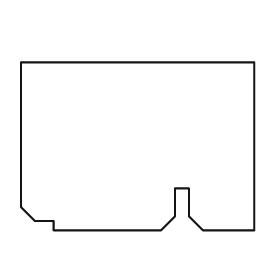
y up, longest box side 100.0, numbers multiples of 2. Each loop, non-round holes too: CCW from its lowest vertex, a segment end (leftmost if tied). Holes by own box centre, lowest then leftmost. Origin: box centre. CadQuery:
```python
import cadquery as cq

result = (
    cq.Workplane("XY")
    .moveTo(-36.0, -36.0)
    .lineTo(10.0, -36.0)
    .lineTo(16.0, -30.0)
    .lineTo(16.0, -18.0)
    .lineTo(22.0, -18.0)
    .lineTo(22.0, -30.0)
    .lineTo(28.0, -36.0)
    .lineTo(50.0, -36.0)
    .lineTo(50.0, 36.0)
    .lineTo(-50.0, 36.0)
    .lineTo(-50.0, -26.0)
    .lineTo(-44.0, -32.0)
    .lineTo(-36.0, -32.0)
    .close()
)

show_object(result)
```